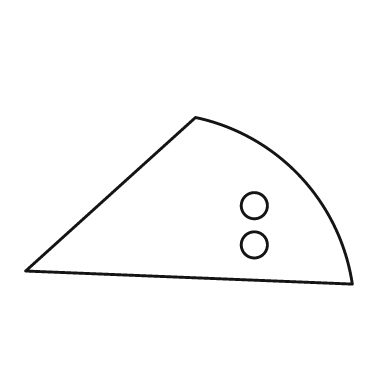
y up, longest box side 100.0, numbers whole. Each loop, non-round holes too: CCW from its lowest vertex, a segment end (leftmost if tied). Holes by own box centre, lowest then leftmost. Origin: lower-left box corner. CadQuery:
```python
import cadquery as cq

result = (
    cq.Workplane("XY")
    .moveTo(100.0, 0.0)
    .threePointArc((84.0, 33.0), (52.0, 51.0))
    .lineTo(0.0, 4.0)
    .close()
    .moveTo(70.0, 12.0)
    .circle(4.0)
    .moveTo(70.0, 24.0)
    .circle(4.0)
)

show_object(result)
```